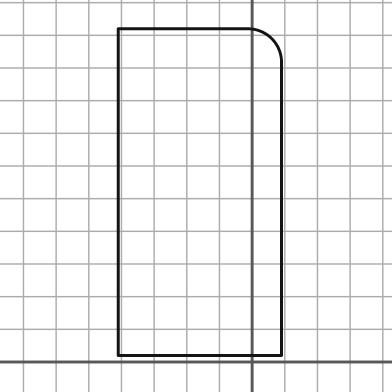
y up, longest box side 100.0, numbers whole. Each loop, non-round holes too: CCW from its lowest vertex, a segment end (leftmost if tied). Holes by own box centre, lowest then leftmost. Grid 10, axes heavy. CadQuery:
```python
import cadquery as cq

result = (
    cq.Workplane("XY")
    .moveTo(-41.0, 2.0)
    .lineTo(9.0, 2.0)
    .lineTo(9.0, 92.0)
    .threePointArc((6.0, 99.0), (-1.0, 102.0))
    .lineTo(-41.0, 102.0)
    .close()
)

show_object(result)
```